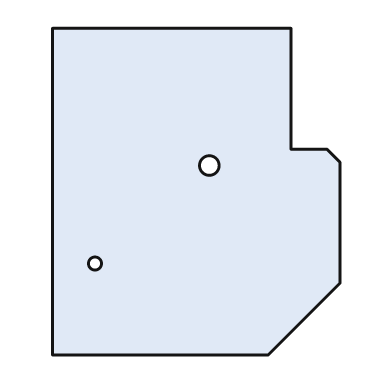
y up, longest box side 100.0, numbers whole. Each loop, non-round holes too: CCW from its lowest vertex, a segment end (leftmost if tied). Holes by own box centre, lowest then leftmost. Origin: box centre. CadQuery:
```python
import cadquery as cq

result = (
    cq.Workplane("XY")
    .moveTo(-44.0, -50.0)
    .lineTo(22.0, -50.0)
    .lineTo(44.0, -28.0)
    .lineTo(44.0, 9.0)
    .lineTo(40.0, 13.0)
    .lineTo(29.0, 13.0)
    .lineTo(29.0, 50.0)
    .lineTo(-44.0, 50.0)
    .close()
    .moveTo(-31.0, -22.0)
    .circle(2.0)
    .moveTo(4.0, 8.0)
    .circle(3.0)
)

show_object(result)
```